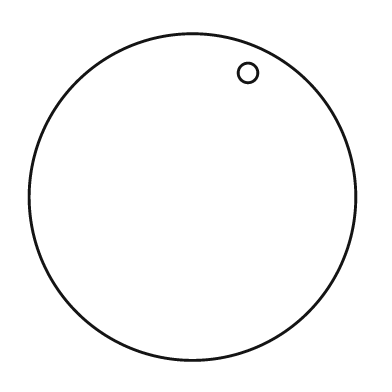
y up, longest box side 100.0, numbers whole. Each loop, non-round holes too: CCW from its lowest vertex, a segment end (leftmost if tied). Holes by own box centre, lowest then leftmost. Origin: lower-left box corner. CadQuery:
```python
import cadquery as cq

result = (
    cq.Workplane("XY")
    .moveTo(50.0, 50.0)
    .circle(50.0)
    .moveTo(67.0, 88.0)
    .circle(3.0)
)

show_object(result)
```